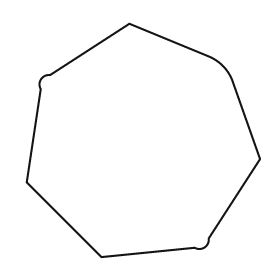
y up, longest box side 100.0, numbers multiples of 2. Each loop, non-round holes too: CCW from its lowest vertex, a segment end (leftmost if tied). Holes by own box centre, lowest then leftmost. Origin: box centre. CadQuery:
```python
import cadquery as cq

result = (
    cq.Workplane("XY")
    .moveTo(-18.0, -50.0)
    .lineTo(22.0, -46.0)
    .threePointArc((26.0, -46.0), (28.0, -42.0))
    .lineTo(50.0, -8.0)
    .lineTo(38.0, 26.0)
    .threePointArc((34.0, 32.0), (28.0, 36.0))
    .lineTo(-6.0, 50.0)
    .lineTo(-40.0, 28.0)
    .threePointArc((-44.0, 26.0), (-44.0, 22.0))
    .lineTo(-50.0, -18.0)
    .close()
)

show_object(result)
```